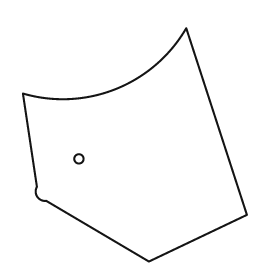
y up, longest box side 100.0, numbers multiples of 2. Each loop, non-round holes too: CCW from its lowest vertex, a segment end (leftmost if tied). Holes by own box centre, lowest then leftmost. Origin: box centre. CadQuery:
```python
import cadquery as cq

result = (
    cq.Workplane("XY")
    .moveTo(6.0, -50.0)
    .lineTo(48.0, -30.0)
    .lineTo(22.0, 50.0)
    .threePointArc((-8.0, 24.0), (-48.0, 22.0))
    .lineTo(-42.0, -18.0)
    .threePointArc((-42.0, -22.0), (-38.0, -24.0))
    .close()
    .moveTo(-24.0, -6.0)
    .circle(2.0)
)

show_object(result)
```